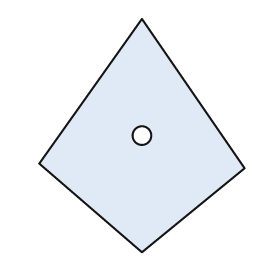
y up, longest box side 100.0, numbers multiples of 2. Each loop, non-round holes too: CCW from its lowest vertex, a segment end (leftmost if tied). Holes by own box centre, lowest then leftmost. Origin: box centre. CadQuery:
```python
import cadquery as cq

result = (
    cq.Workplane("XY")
    .moveTo(0.0, -50.0)
    .lineTo(44.0, -14.0)
    .lineTo(0.0, 50.0)
    .lineTo(-44.0, -12.0)
    .close()
    .moveTo(0.0, 0.0)
    .circle(4.0)
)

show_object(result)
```